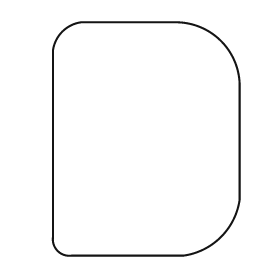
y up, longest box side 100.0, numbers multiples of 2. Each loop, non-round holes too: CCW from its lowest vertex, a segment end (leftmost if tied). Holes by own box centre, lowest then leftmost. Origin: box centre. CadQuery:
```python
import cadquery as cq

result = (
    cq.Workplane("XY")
    .moveTo(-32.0, -50.0)
    .lineTo(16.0, -50.0)
    .threePointArc((32.0, -42.0), (40.0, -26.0))
    .lineTo(40.0, 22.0)
    .threePointArc((32.0, 42.0), (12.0, 50.0))
    .lineTo(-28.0, 50.0)
    .threePointArc((-36.0, 46.0), (-40.0, 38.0))
    .lineTo(-40.0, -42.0)
    .threePointArc((-38.0, -48.0), (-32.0, -50.0))
    .close()
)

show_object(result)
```